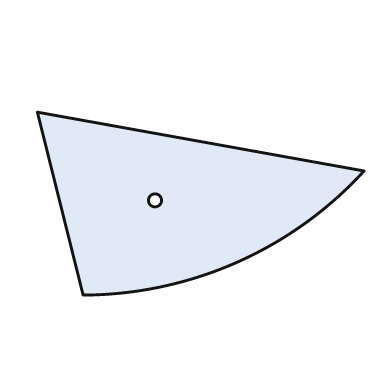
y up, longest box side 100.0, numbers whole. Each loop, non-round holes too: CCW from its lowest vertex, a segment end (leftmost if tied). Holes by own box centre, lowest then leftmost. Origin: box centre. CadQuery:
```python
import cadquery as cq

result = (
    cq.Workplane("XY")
    .moveTo(-36.0, -28.0)
    .threePointArc((11.0, -18.0), (50.0, 10.0))
    .lineTo(-50.0, 28.0)
    .close()
    .moveTo(-14.0, 1.0)
    .circle(2.0)
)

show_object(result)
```